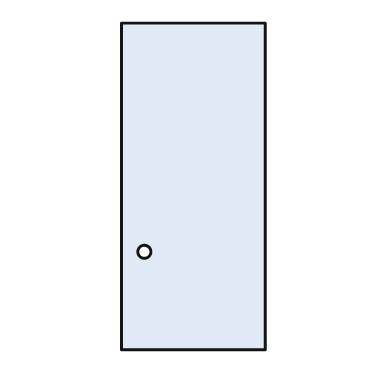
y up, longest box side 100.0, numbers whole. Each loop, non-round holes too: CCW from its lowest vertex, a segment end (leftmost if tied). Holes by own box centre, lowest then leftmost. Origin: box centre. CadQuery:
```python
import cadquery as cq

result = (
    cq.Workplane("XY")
    .moveTo(-22.0, -50.0)
    .lineTo(22.0, -50.0)
    .lineTo(22.0, 50.0)
    .lineTo(-22.0, 50.0)
    .close()
    .moveTo(-15.0, -20.0)
    .circle(2.0)
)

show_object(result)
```